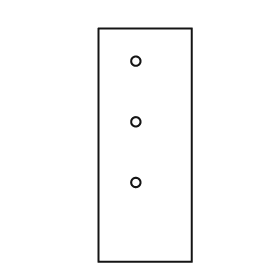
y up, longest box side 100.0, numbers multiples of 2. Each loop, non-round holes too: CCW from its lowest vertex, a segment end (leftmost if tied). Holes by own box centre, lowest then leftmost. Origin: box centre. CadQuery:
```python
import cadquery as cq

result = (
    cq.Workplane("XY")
    .moveTo(-20.0, -50.0)
    .lineTo(20.0, -50.0)
    .lineTo(20.0, 50.0)
    .lineTo(-20.0, 50.0)
    .close()
    .moveTo(-4.0, -16.0)
    .circle(2.0)
    .moveTo(-4.0, 10.0)
    .circle(2.0)
    .moveTo(-4.0, 36.0)
    .circle(2.0)
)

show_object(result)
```